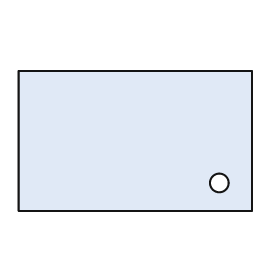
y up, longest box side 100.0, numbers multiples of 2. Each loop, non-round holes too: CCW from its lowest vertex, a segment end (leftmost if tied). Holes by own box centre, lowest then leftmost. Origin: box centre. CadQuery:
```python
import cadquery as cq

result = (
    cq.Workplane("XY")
    .moveTo(-50.0, -30.0)
    .lineTo(50.0, -30.0)
    .lineTo(50.0, 30.0)
    .lineTo(-50.0, 30.0)
    .close()
    .moveTo(36.0, -18.0)
    .circle(4.0)
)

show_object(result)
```